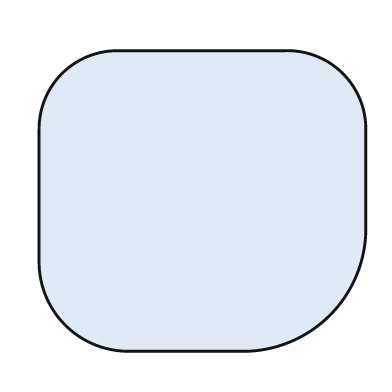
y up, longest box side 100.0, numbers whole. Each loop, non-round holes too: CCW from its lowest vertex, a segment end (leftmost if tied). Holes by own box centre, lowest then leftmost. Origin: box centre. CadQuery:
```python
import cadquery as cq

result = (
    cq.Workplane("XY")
    .moveTo(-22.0, -46.0)
    .lineTo(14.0, -46.0)
    .threePointArc((39.0, -35.0), (50.0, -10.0))
    .lineTo(50.0, 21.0)
    .threePointArc((43.0, 39.0), (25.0, 46.0))
    .lineTo(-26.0, 46.0)
    .threePointArc((-43.0, 39.0), (-50.0, 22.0))
    .lineTo(-50.0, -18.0)
    .threePointArc((-42.0, -38.0), (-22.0, -46.0))
    .close()
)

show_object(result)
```